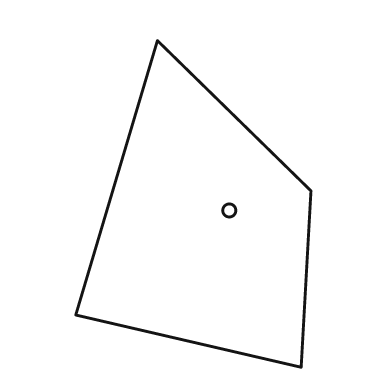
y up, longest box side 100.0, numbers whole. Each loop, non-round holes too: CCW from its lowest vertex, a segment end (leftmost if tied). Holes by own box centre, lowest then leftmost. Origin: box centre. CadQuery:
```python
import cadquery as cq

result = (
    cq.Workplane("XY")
    .moveTo(33.0, -50.0)
    .lineTo(36.0, 4.0)
    .lineTo(-11.0, 50.0)
    .lineTo(-36.0, -34.0)
    .close()
    .moveTo(11.0, -2.0)
    .circle(2.0)
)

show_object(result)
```